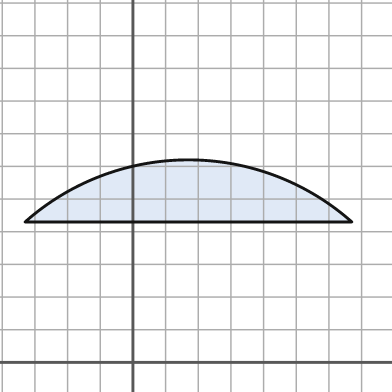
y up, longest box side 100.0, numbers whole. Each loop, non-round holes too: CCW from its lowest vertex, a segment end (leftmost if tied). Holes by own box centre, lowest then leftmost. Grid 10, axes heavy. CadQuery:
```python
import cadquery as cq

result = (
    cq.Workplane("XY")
    .moveTo(-33.0, 43.0)
    .lineTo(67.0, 43.0)
    .threePointArc((17.0, 62.0), (-33.0, 43.0))
    .close()
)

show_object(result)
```